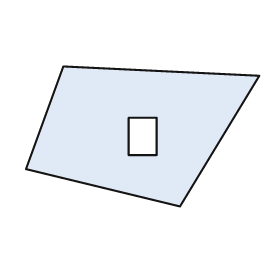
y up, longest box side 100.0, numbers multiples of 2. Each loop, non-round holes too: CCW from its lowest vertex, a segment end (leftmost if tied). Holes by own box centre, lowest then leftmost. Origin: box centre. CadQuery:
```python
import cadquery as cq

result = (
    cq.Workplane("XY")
    .moveTo(16.0, -30.0)
    .lineTo(50.0, 26.0)
    .lineTo(-34.0, 30.0)
    .lineTo(-50.0, -14.0)
    .close()
    .moveTo(-6.0, -8.0)
    .lineTo(6.0, -8.0)
    .lineTo(6.0, 8.0)
    .lineTo(-6.0, 8.0)
    .close()
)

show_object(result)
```